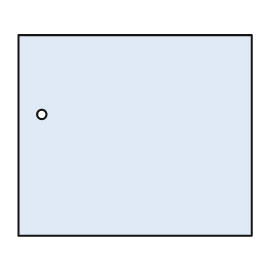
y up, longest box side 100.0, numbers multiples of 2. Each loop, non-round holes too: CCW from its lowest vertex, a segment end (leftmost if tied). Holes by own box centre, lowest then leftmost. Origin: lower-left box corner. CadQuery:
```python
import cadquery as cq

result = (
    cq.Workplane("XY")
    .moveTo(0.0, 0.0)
    .lineTo(100.0, 0.0)
    .lineTo(100.0, 86.0)
    .lineTo(0.0, 86.0)
    .close()
    .moveTo(10.0, 52.0)
    .circle(2.0)
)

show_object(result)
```